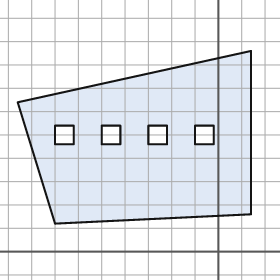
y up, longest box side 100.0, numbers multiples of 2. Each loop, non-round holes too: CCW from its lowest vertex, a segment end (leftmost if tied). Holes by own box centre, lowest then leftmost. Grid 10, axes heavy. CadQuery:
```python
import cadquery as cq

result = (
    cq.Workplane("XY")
    .moveTo(-70.0, 12.0)
    .lineTo(14.0, 16.0)
    .lineTo(14.0, 86.0)
    .lineTo(-86.0, 64.0)
    .close()
    .moveTo(-70.0, 46.0)
    .lineTo(-62.0, 46.0)
    .lineTo(-62.0, 54.0)
    .lineTo(-70.0, 54.0)
    .close()
    .moveTo(-50.0, 46.0)
    .lineTo(-42.0, 46.0)
    .lineTo(-42.0, 54.0)
    .lineTo(-50.0, 54.0)
    .close()
    .moveTo(-30.0, 46.0)
    .lineTo(-22.0, 46.0)
    .lineTo(-22.0, 54.0)
    .lineTo(-30.0, 54.0)
    .close()
    .moveTo(-10.0, 46.0)
    .lineTo(-2.0, 46.0)
    .lineTo(-2.0, 54.0)
    .lineTo(-10.0, 54.0)
    .close()
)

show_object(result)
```